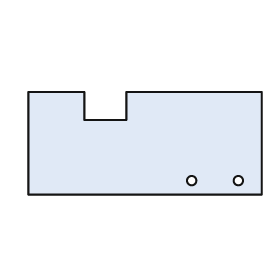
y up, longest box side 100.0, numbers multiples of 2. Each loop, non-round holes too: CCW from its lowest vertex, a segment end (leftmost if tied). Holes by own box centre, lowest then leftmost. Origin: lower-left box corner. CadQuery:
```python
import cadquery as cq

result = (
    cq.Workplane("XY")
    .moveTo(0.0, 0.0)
    .lineTo(100.0, 0.0)
    .lineTo(100.0, 44.0)
    .lineTo(42.0, 44.0)
    .lineTo(42.0, 32.0)
    .lineTo(24.0, 32.0)
    .lineTo(24.0, 44.0)
    .lineTo(0.0, 44.0)
    .close()
    .moveTo(70.0, 6.0)
    .circle(2.0)
    .moveTo(90.0, 6.0)
    .circle(2.0)
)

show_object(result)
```